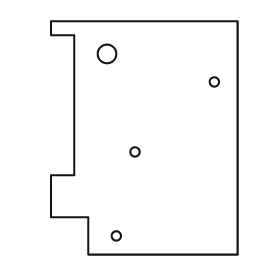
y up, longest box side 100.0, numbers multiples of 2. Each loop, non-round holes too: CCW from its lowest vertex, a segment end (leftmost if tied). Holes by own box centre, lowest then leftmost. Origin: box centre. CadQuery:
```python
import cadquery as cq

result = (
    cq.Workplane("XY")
    .moveTo(-24.0, -50.0)
    .lineTo(40.0, -50.0)
    .lineTo(40.0, 50.0)
    .lineTo(-40.0, 50.0)
    .lineTo(-40.0, 44.0)
    .lineTo(-30.0, 44.0)
    .lineTo(-30.0, -16.0)
    .lineTo(-40.0, -16.0)
    .lineTo(-40.0, -34.0)
    .lineTo(-24.0, -34.0)
    .close()
    .moveTo(-12.0, -42.0)
    .circle(2.0)
    .moveTo(-4.0, -6.0)
    .circle(2.0)
    .moveTo(30.0, 24.0)
    .circle(2.0)
    .moveTo(-16.0, 36.0)
    .circle(4.0)
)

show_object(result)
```